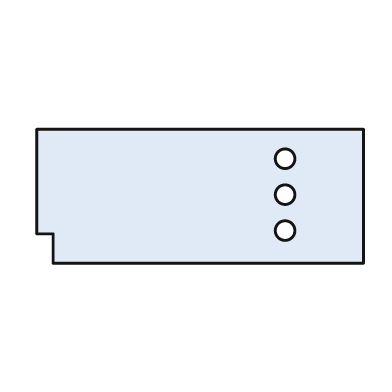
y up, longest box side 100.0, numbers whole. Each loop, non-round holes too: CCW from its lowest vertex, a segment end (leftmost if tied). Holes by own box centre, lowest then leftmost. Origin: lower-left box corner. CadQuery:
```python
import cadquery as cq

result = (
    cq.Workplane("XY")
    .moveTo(5.0, 0.0)
    .lineTo(100.0, 0.0)
    .lineTo(100.0, 41.0)
    .lineTo(0.0, 41.0)
    .lineTo(0.0, 9.0)
    .lineTo(5.0, 9.0)
    .close()
    .moveTo(76.0, 10.0)
    .circle(3.0)
    .moveTo(76.0, 21.0)
    .circle(3.0)
    .moveTo(76.0, 32.0)
    .circle(3.0)
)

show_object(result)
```